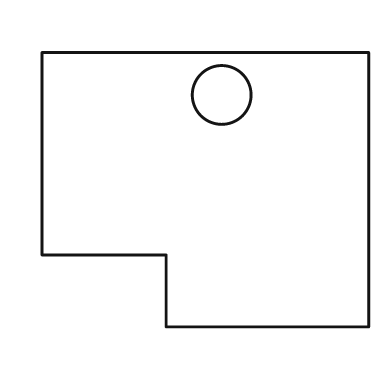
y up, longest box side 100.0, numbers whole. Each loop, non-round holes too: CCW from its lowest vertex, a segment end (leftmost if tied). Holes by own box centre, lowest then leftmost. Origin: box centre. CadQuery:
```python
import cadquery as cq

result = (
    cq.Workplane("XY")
    .moveTo(-12.0, -42.0)
    .lineTo(50.0, -42.0)
    .lineTo(50.0, 42.0)
    .lineTo(-50.0, 42.0)
    .lineTo(-50.0, -20.0)
    .lineTo(-12.0, -20.0)
    .close()
    .moveTo(5.0, 29.0)
    .circle(9.0)
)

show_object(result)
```